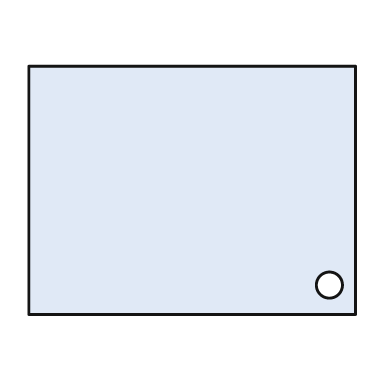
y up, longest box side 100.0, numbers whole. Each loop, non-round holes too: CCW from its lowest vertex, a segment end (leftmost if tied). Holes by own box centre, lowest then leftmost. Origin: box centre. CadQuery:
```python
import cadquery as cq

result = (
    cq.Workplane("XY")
    .moveTo(-50.0, -38.0)
    .lineTo(50.0, -38.0)
    .lineTo(50.0, 38.0)
    .lineTo(-50.0, 38.0)
    .close()
    .moveTo(42.0, -29.0)
    .circle(4.0)
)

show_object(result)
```